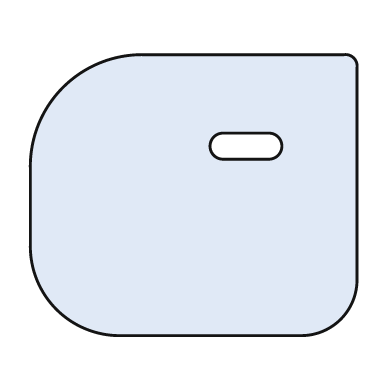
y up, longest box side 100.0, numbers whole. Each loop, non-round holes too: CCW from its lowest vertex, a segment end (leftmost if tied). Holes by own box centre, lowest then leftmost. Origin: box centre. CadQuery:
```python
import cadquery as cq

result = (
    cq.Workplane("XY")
    .moveTo(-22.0, -43.0)
    .lineTo(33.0, -43.0)
    .threePointArc((45.0, -38.0), (50.0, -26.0))
    .lineTo(50.0, 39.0)
    .threePointArc((49.0, 42.0), (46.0, 43.0))
    .lineTo(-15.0, 43.0)
    .threePointArc((-40.0, 33.0), (-50.0, 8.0))
    .lineTo(-50.0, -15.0)
    .threePointArc((-42.0, -35.0), (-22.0, -43.0))
    .close()
    .moveTo(9.0, 11.0)
    .lineTo(23.0, 11.0)
    .threePointArc((27.0, 15.0), (23.0, 19.0))
    .lineTo(9.0, 19.0)
    .threePointArc((5.0, 15.0), (9.0, 11.0))
    .close()
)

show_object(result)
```